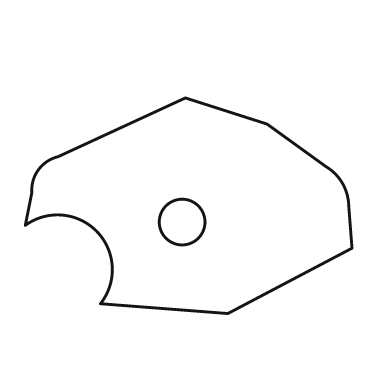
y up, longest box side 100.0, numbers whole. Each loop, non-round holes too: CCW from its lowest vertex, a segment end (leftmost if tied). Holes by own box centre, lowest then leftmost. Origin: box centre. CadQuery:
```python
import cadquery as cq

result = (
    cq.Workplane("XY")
    .moveTo(12.0, -33.0)
    .lineTo(50.0, -13.0)
    .lineTo(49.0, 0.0)
    .threePointArc((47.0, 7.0), (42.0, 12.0))
    .lineTo(24.0, 25.0)
    .lineTo(-1.0, 33.0)
    .lineTo(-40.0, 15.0)
    .threePointArc((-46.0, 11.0), (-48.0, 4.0))
    .lineTo(-50.0, -6.0)
    .threePointArc((-28.0, -8.0), (-27.0, -30.0))
    .close()
    .moveTo(-2.0, -5.0)
    .circle(7.0)
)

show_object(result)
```